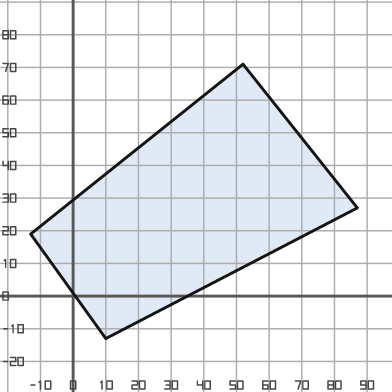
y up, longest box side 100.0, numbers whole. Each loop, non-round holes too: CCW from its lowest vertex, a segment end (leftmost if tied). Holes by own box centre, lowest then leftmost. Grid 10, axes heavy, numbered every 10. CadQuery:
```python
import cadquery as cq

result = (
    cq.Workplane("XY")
    .moveTo(10.0, -13.0)
    .lineTo(87.0, 27.0)
    .lineTo(52.0, 71.0)
    .lineTo(-13.0, 19.0)
    .close()
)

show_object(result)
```